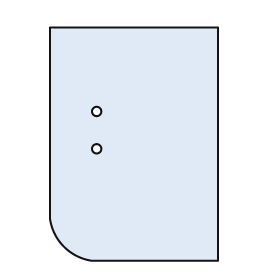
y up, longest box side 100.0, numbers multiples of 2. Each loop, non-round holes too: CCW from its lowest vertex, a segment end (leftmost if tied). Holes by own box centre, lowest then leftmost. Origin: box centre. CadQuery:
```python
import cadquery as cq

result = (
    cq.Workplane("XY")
    .moveTo(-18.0, -50.0)
    .lineTo(36.0, -50.0)
    .lineTo(36.0, 50.0)
    .lineTo(-36.0, 50.0)
    .lineTo(-36.0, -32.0)
    .threePointArc((-30.0, -44.0), (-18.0, -50.0))
    .close()
    .moveTo(-16.0, -2.0)
    .circle(2.0)
    .moveTo(-16.0, 14.0)
    .circle(2.0)
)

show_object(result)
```